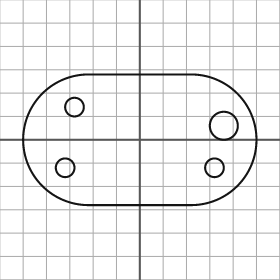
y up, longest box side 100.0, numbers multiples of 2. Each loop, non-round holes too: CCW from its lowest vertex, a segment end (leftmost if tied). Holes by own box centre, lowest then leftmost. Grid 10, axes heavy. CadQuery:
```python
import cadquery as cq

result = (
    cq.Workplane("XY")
    .moveTo(-22.0, -28.0)
    .lineTo(22.0, -28.0)
    .threePointArc((50.0, 0.0), (22.0, 28.0))
    .lineTo(-22.0, 28.0)
    .threePointArc((-50.0, 0.0), (-22.0, -28.0))
    .close()
    .moveTo(-32.0, -12.0)
    .circle(4.0)
    .moveTo(32.0, -12.0)
    .circle(4.0)
    .moveTo(36.0, 6.0)
    .circle(6.0)
    .moveTo(-28.0, 14.0)
    .circle(4.0)
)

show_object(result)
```